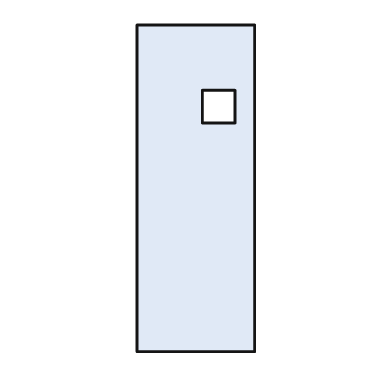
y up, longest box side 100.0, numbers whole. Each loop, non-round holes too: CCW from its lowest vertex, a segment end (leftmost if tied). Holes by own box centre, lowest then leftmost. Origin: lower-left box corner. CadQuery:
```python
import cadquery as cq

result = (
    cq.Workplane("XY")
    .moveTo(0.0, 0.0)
    .lineTo(36.0, 0.0)
    .lineTo(36.0, 100.0)
    .lineTo(0.0, 100.0)
    .close()
    .moveTo(20.0, 70.0)
    .lineTo(30.0, 70.0)
    .lineTo(30.0, 80.0)
    .lineTo(20.0, 80.0)
    .close()
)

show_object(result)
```